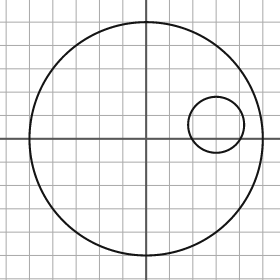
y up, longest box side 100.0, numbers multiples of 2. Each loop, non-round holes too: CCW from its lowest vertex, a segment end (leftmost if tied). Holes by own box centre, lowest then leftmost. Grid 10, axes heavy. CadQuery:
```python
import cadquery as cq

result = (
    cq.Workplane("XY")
    .moveTo(0.0, 0.0)
    .circle(50.0)
    .moveTo(30.0, 6.0)
    .circle(12.0)
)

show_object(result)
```